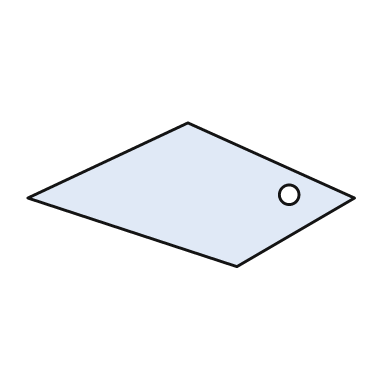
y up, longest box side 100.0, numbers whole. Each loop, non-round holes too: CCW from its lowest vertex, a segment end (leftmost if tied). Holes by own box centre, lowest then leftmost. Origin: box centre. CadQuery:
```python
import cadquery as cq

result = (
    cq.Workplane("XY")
    .moveTo(14.0, -22.0)
    .lineTo(50.0, -1.0)
    .lineTo(-1.0, 22.0)
    .lineTo(-50.0, -1.0)
    .close()
    .moveTo(30.0, 0.0)
    .circle(3.0)
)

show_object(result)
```